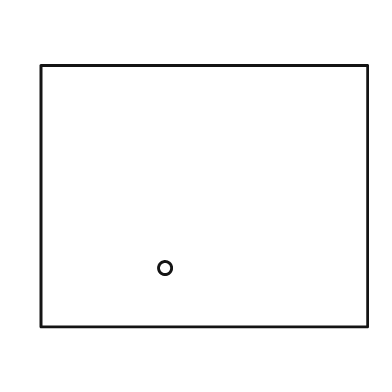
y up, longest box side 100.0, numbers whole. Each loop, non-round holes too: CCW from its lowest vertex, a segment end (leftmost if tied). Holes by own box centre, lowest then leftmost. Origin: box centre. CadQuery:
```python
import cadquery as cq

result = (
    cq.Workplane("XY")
    .moveTo(-50.0, -40.0)
    .lineTo(50.0, -40.0)
    .lineTo(50.0, 40.0)
    .lineTo(-50.0, 40.0)
    .close()
    .moveTo(-12.0, -22.0)
    .circle(2.0)
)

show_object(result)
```